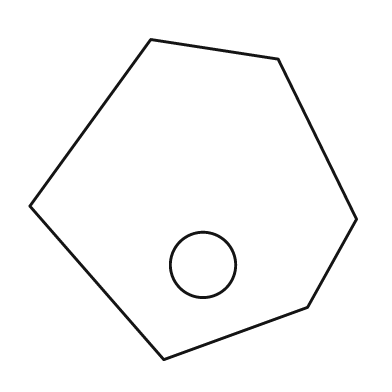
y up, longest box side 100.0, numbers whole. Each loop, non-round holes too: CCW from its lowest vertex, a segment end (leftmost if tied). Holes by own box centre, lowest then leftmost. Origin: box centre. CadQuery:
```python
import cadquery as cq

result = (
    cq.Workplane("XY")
    .moveTo(-9.0, -49.0)
    .lineTo(35.0, -33.0)
    .lineTo(50.0, -6.0)
    .lineTo(26.0, 43.0)
    .lineTo(-13.0, 49.0)
    .lineTo(-50.0, -2.0)
    .close()
    .moveTo(3.0, -20.0)
    .circle(10.0)
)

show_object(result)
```